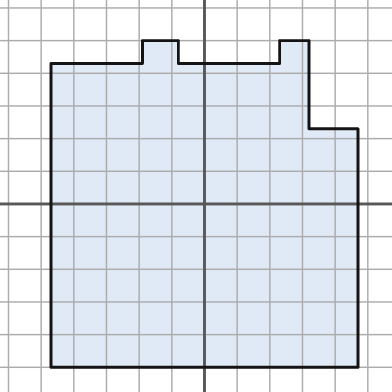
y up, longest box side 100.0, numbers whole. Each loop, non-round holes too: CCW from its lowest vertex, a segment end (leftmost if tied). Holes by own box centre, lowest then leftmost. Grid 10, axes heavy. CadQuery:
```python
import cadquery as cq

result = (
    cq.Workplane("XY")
    .moveTo(-47.0, -50.0)
    .lineTo(47.0, -50.0)
    .lineTo(47.0, 23.0)
    .lineTo(32.0, 23.0)
    .lineTo(32.0, 50.0)
    .lineTo(23.0, 50.0)
    .lineTo(23.0, 43.0)
    .lineTo(-8.0, 43.0)
    .lineTo(-8.0, 50.0)
    .lineTo(-19.0, 50.0)
    .lineTo(-19.0, 43.0)
    .lineTo(-47.0, 43.0)
    .close()
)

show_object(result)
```